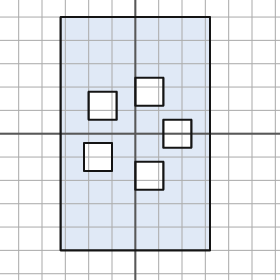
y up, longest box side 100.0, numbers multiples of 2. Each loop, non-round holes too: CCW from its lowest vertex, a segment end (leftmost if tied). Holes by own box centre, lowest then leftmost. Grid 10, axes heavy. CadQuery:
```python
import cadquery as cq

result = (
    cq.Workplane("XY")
    .moveTo(-32.0, -50.0)
    .lineTo(32.0, -50.0)
    .lineTo(32.0, 50.0)
    .lineTo(-32.0, 50.0)
    .close()
    .moveTo(0.0, -24.0)
    .lineTo(12.0, -24.0)
    .lineTo(12.0, -12.0)
    .lineTo(0.0, -12.0)
    .close()
    .moveTo(-22.0, -16.0)
    .lineTo(-10.0, -16.0)
    .lineTo(-10.0, -4.0)
    .lineTo(-22.0, -4.0)
    .close()
    .moveTo(12.0, -6.0)
    .lineTo(24.0, -6.0)
    .lineTo(24.0, 6.0)
    .lineTo(12.0, 6.0)
    .close()
    .moveTo(-20.0, 6.0)
    .lineTo(-8.0, 6.0)
    .lineTo(-8.0, 18.0)
    .lineTo(-20.0, 18.0)
    .close()
    .moveTo(0.0, 12.0)
    .lineTo(12.0, 12.0)
    .lineTo(12.0, 24.0)
    .lineTo(0.0, 24.0)
    .close()
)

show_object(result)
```